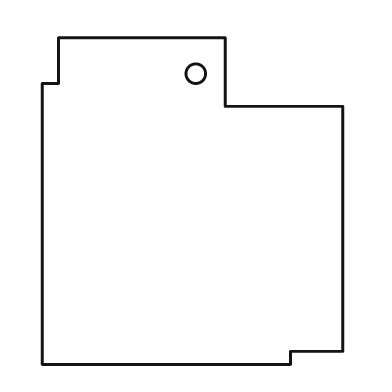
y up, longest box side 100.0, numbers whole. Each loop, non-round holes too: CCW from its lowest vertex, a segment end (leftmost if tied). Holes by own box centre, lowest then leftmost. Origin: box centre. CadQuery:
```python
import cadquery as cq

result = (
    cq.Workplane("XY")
    .moveTo(-46.0, -50.0)
    .lineTo(30.0, -50.0)
    .lineTo(30.0, -46.0)
    .lineTo(46.0, -46.0)
    .lineTo(46.0, 29.0)
    .lineTo(10.0, 29.0)
    .lineTo(10.0, 50.0)
    .lineTo(-41.0, 50.0)
    .lineTo(-41.0, 36.0)
    .lineTo(-46.0, 36.0)
    .close()
    .moveTo(1.0, 39.0)
    .circle(3.0)
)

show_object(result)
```